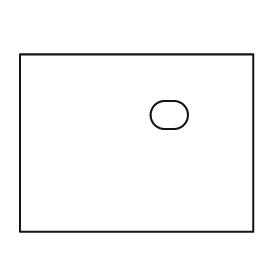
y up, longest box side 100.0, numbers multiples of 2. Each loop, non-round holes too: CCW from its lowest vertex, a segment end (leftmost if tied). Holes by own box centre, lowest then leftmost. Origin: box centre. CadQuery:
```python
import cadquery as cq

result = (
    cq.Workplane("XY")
    .moveTo(-50.0, -38.0)
    .lineTo(50.0, -38.0)
    .lineTo(50.0, 38.0)
    .lineTo(-50.0, 38.0)
    .close()
    .moveTo(12.0, 6.0)
    .lineTo(16.0, 6.0)
    .threePointArc((22.0, 12.0), (16.0, 18.0))
    .lineTo(12.0, 18.0)
    .threePointArc((6.0, 12.0), (12.0, 6.0))
    .close()
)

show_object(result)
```